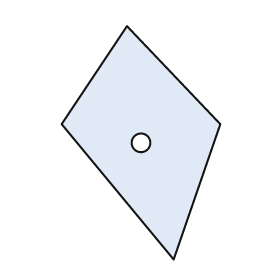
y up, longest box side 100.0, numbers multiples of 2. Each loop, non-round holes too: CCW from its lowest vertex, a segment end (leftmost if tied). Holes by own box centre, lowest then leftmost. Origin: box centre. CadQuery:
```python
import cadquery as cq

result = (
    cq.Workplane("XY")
    .moveTo(14.0, -50.0)
    .lineTo(34.0, 8.0)
    .lineTo(-6.0, 50.0)
    .lineTo(-34.0, 8.0)
    .close()
    .moveTo(0.0, 0.0)
    .circle(4.0)
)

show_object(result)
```